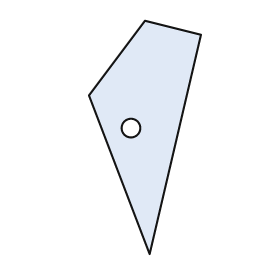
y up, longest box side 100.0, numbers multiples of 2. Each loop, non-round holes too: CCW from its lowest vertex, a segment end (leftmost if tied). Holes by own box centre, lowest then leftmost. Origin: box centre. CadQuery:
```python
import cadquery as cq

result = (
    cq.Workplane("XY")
    .moveTo(2.0, -50.0)
    .lineTo(24.0, 44.0)
    .lineTo(0.0, 50.0)
    .lineTo(-24.0, 18.0)
    .close()
    .moveTo(-6.0, 4.0)
    .circle(4.0)
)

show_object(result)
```